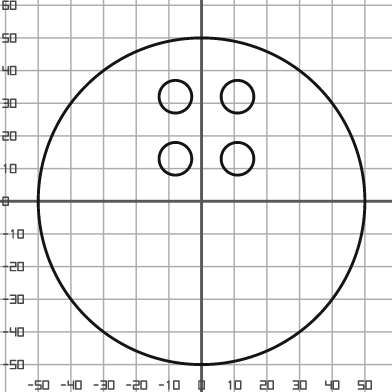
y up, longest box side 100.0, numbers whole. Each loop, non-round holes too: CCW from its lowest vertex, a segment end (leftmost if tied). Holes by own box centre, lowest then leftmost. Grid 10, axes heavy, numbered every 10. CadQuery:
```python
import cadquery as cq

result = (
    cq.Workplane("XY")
    .moveTo(0.0, 0.0)
    .circle(50.0)
    .moveTo(-8.0, 13.0)
    .circle(5.0)
    .moveTo(11.0, 13.0)
    .circle(5.0)
    .moveTo(-8.0, 32.0)
    .circle(5.0)
    .moveTo(11.0, 32.0)
    .circle(5.0)
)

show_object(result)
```